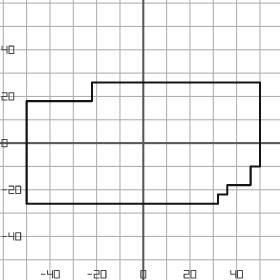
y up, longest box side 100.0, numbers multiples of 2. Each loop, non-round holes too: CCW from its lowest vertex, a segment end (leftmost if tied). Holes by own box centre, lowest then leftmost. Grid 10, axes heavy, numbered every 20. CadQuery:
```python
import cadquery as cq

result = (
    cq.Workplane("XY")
    .moveTo(-50.0, -26.0)
    .lineTo(32.0, -26.0)
    .lineTo(32.0, -22.0)
    .lineTo(36.0, -22.0)
    .lineTo(36.0, -18.0)
    .lineTo(46.0, -18.0)
    .lineTo(46.0, -10.0)
    .lineTo(50.0, -10.0)
    .lineTo(50.0, 26.0)
    .lineTo(-22.0, 26.0)
    .lineTo(-22.0, 18.0)
    .lineTo(-50.0, 18.0)
    .close()
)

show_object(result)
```